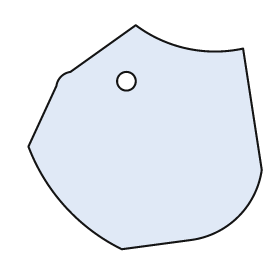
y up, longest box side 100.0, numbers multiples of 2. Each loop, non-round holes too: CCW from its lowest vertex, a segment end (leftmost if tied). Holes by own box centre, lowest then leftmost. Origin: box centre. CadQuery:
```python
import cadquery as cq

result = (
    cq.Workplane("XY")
    .moveTo(-10.0, -48.0)
    .lineTo(20.0, -44.0)
    .threePointArc((40.0, -34.0), (50.0, -14.0))
    .lineTo(42.0, 38.0)
    .threePointArc((18.0, 38.0), (-4.0, 48.0))
    .lineTo(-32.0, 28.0)
    .threePointArc((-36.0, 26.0), (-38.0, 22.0))
    .lineTo(-50.0, -4.0)
    .threePointArc((-34.0, -30.0), (-10.0, -48.0))
    .close()
    .moveTo(-8.0, 24.0)
    .circle(4.0)
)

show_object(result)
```